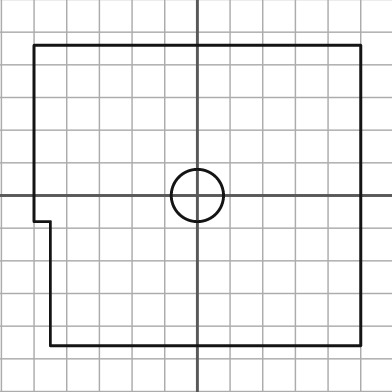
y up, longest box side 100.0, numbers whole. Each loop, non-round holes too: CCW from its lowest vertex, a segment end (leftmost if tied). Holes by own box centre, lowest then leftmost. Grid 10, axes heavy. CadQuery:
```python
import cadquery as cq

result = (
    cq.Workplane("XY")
    .moveTo(-45.0, -46.0)
    .lineTo(50.0, -46.0)
    .lineTo(50.0, 46.0)
    .lineTo(-50.0, 46.0)
    .lineTo(-50.0, -8.0)
    .lineTo(-45.0, -8.0)
    .close()
    .moveTo(0.0, 0.0)
    .circle(8.0)
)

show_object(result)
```